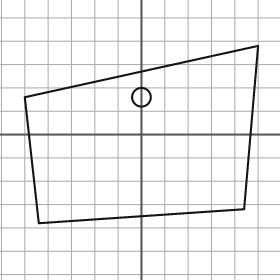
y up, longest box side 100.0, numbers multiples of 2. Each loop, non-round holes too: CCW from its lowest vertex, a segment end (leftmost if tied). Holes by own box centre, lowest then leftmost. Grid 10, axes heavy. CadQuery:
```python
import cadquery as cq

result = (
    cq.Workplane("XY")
    .moveTo(-44.0, -38.0)
    .lineTo(44.0, -32.0)
    .lineTo(50.0, 38.0)
    .lineTo(-50.0, 16.0)
    .close()
    .moveTo(0.0, 16.0)
    .circle(4.0)
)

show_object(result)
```